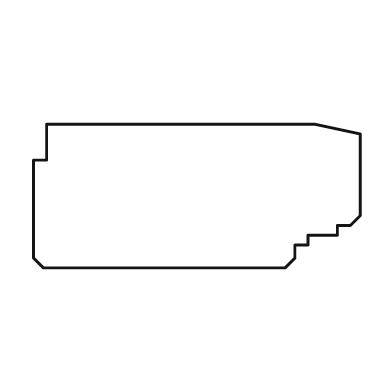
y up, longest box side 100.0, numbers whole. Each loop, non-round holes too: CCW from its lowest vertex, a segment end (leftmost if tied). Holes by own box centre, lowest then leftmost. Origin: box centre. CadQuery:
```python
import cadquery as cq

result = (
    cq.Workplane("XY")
    .moveTo(-47.0, -22.0)
    .lineTo(27.0, -22.0)
    .lineTo(30.0, -19.0)
    .lineTo(30.0, -15.0)
    .lineTo(34.0, -15.0)
    .lineTo(34.0, -12.0)
    .lineTo(43.0, -12.0)
    .lineTo(43.0, -9.0)
    .lineTo(47.0, -9.0)
    .lineTo(50.0, -6.0)
    .lineTo(50.0, 19.0)
    .lineTo(36.0, 22.0)
    .lineTo(-46.0, 22.0)
    .lineTo(-46.0, 11.0)
    .lineTo(-50.0, 11.0)
    .lineTo(-50.0, -19.0)
    .close()
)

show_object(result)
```